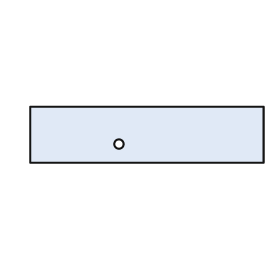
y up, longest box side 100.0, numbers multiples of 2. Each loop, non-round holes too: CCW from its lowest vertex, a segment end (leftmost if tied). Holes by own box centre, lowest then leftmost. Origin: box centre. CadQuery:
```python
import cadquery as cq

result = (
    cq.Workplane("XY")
    .moveTo(-50.0, -12.0)
    .lineTo(50.0, -12.0)
    .lineTo(50.0, 12.0)
    .lineTo(-50.0, 12.0)
    .close()
    .moveTo(-12.0, -4.0)
    .circle(2.0)
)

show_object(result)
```